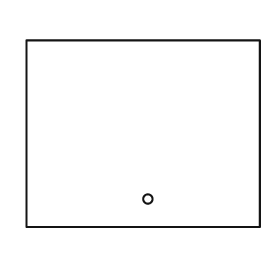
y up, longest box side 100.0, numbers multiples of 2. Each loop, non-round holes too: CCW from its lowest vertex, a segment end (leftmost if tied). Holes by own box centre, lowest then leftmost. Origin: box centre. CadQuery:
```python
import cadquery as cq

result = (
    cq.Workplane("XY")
    .moveTo(-50.0, -40.0)
    .lineTo(50.0, -40.0)
    .lineTo(50.0, 40.0)
    .lineTo(-50.0, 40.0)
    .close()
    .moveTo(2.0, -28.0)
    .circle(2.0)
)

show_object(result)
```